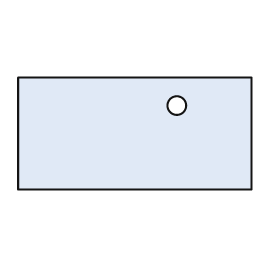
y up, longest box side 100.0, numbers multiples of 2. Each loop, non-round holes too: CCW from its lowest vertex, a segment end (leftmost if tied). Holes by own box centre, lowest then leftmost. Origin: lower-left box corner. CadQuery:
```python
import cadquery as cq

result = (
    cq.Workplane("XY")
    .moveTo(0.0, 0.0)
    .lineTo(100.0, 0.0)
    .lineTo(100.0, 48.0)
    .lineTo(0.0, 48.0)
    .close()
    .moveTo(68.0, 36.0)
    .circle(4.0)
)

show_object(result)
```